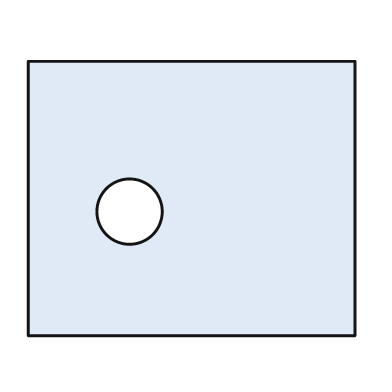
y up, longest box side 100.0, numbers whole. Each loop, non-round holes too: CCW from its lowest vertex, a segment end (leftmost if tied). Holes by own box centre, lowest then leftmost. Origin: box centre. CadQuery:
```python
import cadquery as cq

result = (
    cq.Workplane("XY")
    .moveTo(-50.0, -42.0)
    .lineTo(50.0, -42.0)
    .lineTo(50.0, 42.0)
    .lineTo(-50.0, 42.0)
    .close()
    .moveTo(-19.0, -4.0)
    .circle(10.0)
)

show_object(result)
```